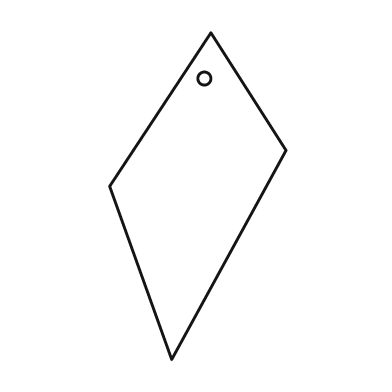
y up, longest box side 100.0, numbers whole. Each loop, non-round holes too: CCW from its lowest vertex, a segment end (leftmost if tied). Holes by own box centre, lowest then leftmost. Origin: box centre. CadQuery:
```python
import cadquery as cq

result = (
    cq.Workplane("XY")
    .moveTo(-8.0, -50.0)
    .lineTo(27.0, 14.0)
    .lineTo(4.0, 50.0)
    .lineTo(-27.0, 3.0)
    .close()
    .moveTo(2.0, 36.0)
    .circle(2.0)
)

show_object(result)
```